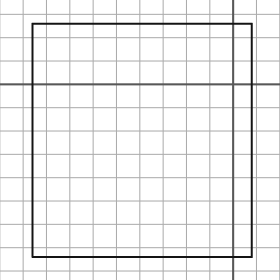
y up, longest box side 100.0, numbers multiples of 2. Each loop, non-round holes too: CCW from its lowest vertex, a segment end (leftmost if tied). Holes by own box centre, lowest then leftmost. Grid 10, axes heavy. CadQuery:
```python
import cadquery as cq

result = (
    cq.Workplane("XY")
    .moveTo(-86.0, -74.0)
    .lineTo(8.0, -74.0)
    .lineTo(8.0, 26.0)
    .lineTo(-86.0, 26.0)
    .close()
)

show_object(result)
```